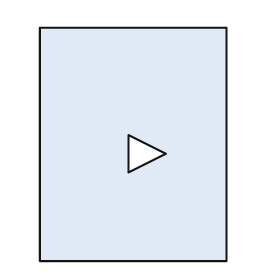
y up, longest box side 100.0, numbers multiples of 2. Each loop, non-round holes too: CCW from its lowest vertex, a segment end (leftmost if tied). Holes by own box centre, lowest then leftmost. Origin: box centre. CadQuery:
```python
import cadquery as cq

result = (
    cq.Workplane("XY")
    .moveTo(-40.0, -50.0)
    .lineTo(40.0, -50.0)
    .lineTo(40.0, 50.0)
    .lineTo(-40.0, 50.0)
    .close()
    .moveTo(-2.0, -12.0)
    .lineTo(14.0, -4.0)
    .lineTo(-2.0, 4.0)
    .close()
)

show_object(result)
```